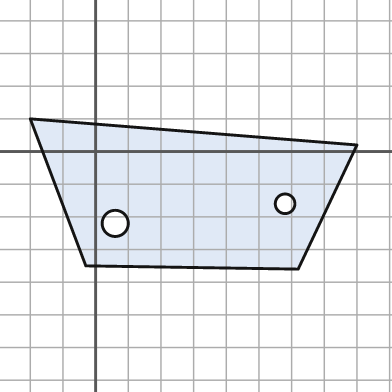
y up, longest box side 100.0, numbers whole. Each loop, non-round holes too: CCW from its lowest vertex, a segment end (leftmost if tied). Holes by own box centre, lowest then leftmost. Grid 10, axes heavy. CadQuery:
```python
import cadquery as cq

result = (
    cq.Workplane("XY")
    .moveTo(62.0, -36.0)
    .lineTo(80.0, 2.0)
    .lineTo(-20.0, 10.0)
    .lineTo(-3.0, -35.0)
    .close()
    .moveTo(6.0, -22.0)
    .circle(4.0)
    .moveTo(58.0, -16.0)
    .circle(3.0)
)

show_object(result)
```